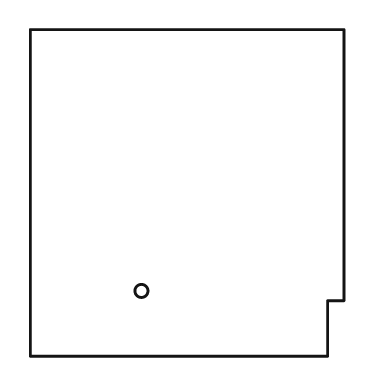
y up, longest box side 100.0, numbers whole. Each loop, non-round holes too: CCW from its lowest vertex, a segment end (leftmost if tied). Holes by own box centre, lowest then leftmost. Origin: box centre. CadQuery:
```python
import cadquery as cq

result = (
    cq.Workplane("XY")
    .moveTo(-48.0, -50.0)
    .lineTo(43.0, -50.0)
    .lineTo(43.0, -33.0)
    .lineTo(48.0, -33.0)
    .lineTo(48.0, 50.0)
    .lineTo(-48.0, 50.0)
    .close()
    .moveTo(-14.0, -30.0)
    .circle(2.0)
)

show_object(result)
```